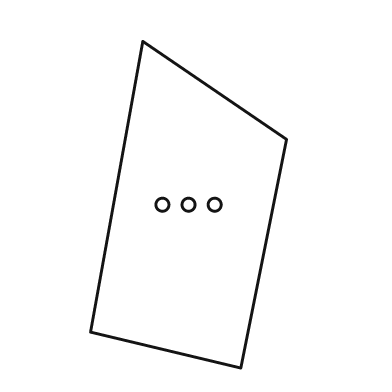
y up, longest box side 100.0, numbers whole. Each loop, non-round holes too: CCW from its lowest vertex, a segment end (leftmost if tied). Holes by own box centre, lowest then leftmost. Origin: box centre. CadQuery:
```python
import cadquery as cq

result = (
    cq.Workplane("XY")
    .moveTo(16.0, -50.0)
    .lineTo(30.0, 20.0)
    .lineTo(-14.0, 50.0)
    .lineTo(-30.0, -39.0)
    .close()
    .moveTo(-8.0, 0.0)
    .circle(2.0)
    .moveTo(0.0, 0.0)
    .circle(2.0)
    .moveTo(8.0, 0.0)
    .circle(2.0)
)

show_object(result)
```